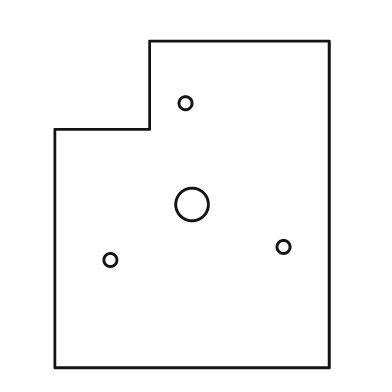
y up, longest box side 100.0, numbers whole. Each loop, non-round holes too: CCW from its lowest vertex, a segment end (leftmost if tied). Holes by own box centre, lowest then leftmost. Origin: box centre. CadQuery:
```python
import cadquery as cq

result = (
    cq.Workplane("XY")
    .moveTo(-42.0, -50.0)
    .lineTo(42.0, -50.0)
    .lineTo(42.0, 50.0)
    .lineTo(-13.0, 50.0)
    .lineTo(-13.0, 23.0)
    .lineTo(-42.0, 23.0)
    .close()
    .moveTo(-25.0, -17.0)
    .circle(2.0)
    .moveTo(28.0, -13.0)
    .circle(2.0)
    .moveTo(0.0, 0.0)
    .circle(5.0)
    .moveTo(-2.0, 31.0)
    .circle(2.0)
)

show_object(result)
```